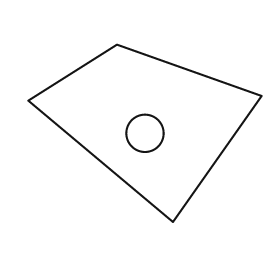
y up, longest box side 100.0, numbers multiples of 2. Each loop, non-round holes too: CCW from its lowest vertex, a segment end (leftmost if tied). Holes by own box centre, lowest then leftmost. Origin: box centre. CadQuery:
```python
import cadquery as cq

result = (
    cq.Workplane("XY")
    .moveTo(12.0, -38.0)
    .lineTo(50.0, 16.0)
    .lineTo(-12.0, 38.0)
    .lineTo(-50.0, 14.0)
    .close()
    .moveTo(0.0, 0.0)
    .circle(8.0)
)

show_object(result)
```